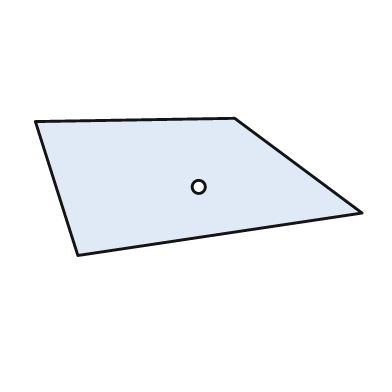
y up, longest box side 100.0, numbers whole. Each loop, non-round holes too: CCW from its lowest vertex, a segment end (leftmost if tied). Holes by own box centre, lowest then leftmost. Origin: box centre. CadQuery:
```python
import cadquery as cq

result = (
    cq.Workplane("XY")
    .moveTo(-37.0, -21.0)
    .lineTo(50.0, -8.0)
    .lineTo(11.0, 21.0)
    .lineTo(-50.0, 20.0)
    .close()
    .moveTo(0.0, 0.0)
    .circle(2.0)
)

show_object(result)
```